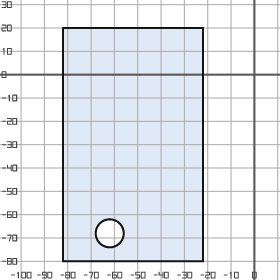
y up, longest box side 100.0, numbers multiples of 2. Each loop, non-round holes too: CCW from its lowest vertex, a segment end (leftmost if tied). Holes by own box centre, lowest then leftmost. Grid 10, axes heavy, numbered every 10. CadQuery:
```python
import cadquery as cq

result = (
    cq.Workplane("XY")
    .moveTo(-82.0, -80.0)
    .lineTo(-22.0, -80.0)
    .lineTo(-22.0, 20.0)
    .lineTo(-82.0, 20.0)
    .close()
    .moveTo(-62.0, -68.0)
    .circle(6.0)
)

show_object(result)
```